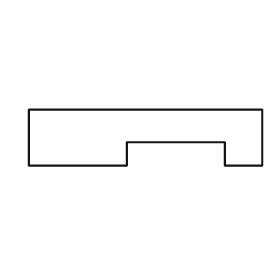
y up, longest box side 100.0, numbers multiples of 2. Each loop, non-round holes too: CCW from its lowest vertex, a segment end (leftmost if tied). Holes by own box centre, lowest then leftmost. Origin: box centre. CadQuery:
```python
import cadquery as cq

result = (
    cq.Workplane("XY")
    .moveTo(-50.0, -12.0)
    .lineTo(-8.0, -12.0)
    .lineTo(-8.0, -2.0)
    .lineTo(34.0, -2.0)
    .lineTo(34.0, -12.0)
    .lineTo(50.0, -12.0)
    .lineTo(50.0, 12.0)
    .lineTo(-50.0, 12.0)
    .close()
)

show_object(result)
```